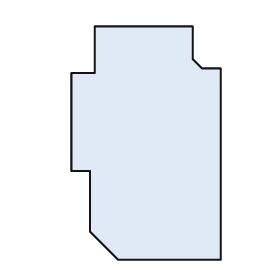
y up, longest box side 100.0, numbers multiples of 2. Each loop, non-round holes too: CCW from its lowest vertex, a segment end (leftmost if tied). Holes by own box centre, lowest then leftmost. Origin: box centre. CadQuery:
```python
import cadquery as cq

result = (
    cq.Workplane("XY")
    .moveTo(-12.0, -50.0)
    .lineTo(32.0, -50.0)
    .lineTo(32.0, 32.0)
    .lineTo(24.0, 32.0)
    .lineTo(20.0, 36.0)
    .lineTo(20.0, 50.0)
    .lineTo(-22.0, 50.0)
    .lineTo(-22.0, 30.0)
    .lineTo(-32.0, 30.0)
    .lineTo(-32.0, -12.0)
    .lineTo(-24.0, -12.0)
    .lineTo(-24.0, -38.0)
    .close()
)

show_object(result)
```